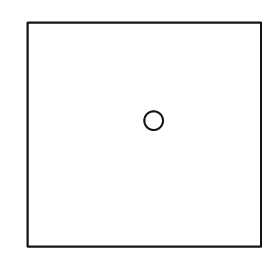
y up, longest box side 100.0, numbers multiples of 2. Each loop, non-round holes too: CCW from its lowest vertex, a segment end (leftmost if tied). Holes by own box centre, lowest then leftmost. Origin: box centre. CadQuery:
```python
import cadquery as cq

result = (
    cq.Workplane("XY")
    .moveTo(-50.0, -48.0)
    .lineTo(50.0, -48.0)
    .lineTo(50.0, 48.0)
    .lineTo(-50.0, 48.0)
    .close()
    .moveTo(4.0, 6.0)
    .circle(4.0)
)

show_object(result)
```